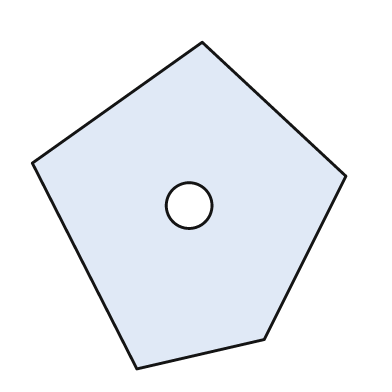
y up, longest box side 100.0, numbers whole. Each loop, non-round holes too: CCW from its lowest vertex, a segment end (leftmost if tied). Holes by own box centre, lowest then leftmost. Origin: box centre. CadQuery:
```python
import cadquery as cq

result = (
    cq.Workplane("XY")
    .moveTo(-16.0, -50.0)
    .lineTo(23.0, -41.0)
    .lineTo(48.0, 9.0)
    .lineTo(4.0, 50.0)
    .lineTo(-48.0, 13.0)
    .close()
    .moveTo(0.0, 0.0)
    .circle(7.0)
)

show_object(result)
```